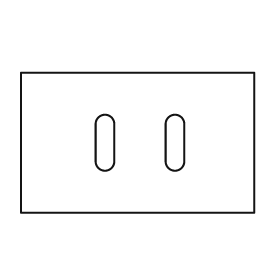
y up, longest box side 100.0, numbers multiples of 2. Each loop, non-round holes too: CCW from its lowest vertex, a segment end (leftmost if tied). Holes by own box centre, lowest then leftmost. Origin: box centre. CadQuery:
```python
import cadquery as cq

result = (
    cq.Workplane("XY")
    .moveTo(-50.0, -30.0)
    .lineTo(50.0, -30.0)
    .lineTo(50.0, 30.0)
    .lineTo(-50.0, 30.0)
    .close()
    .moveTo(-18.0, -8.0)
    .threePointArc((-14.0, -12.0), (-10.0, -8.0))
    .lineTo(-10.0, 8.0)
    .threePointArc((-14.0, 12.0), (-18.0, 8.0))
    .close()
    .moveTo(12.0, -8.0)
    .threePointArc((16.0, -12.0), (20.0, -8.0))
    .lineTo(20.0, 8.0)
    .threePointArc((16.0, 12.0), (12.0, 8.0))
    .close()
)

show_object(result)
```